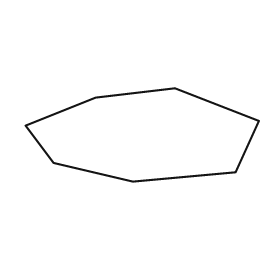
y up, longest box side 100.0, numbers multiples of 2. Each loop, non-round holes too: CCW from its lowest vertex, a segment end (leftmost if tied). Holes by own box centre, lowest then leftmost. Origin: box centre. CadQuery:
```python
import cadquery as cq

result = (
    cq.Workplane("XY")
    .moveTo(-4.0, -20.0)
    .lineTo(40.0, -16.0)
    .lineTo(50.0, 6.0)
    .lineTo(14.0, 20.0)
    .lineTo(-20.0, 16.0)
    .lineTo(-50.0, 4.0)
    .lineTo(-38.0, -12.0)
    .close()
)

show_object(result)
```